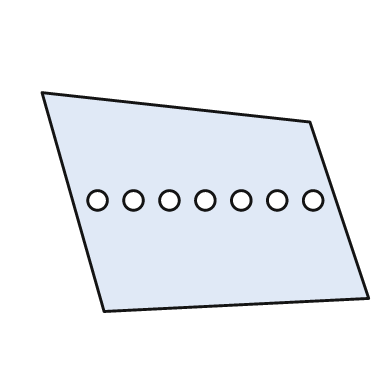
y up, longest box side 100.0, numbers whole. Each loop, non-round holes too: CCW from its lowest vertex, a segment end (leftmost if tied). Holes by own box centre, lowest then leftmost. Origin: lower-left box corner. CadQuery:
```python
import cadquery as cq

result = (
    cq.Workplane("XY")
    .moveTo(19.0, 0.0)
    .lineTo(100.0, 4.0)
    .lineTo(82.0, 58.0)
    .lineTo(0.0, 67.0)
    .close()
    .moveTo(17.0, 34.0)
    .circle(3.0)
    .moveTo(28.0, 34.0)
    .circle(3.0)
    .moveTo(39.0, 34.0)
    .circle(3.0)
    .moveTo(50.0, 34.0)
    .circle(3.0)
    .moveTo(61.0, 34.0)
    .circle(3.0)
    .moveTo(72.0, 34.0)
    .circle(3.0)
    .moveTo(83.0, 34.0)
    .circle(3.0)
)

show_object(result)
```